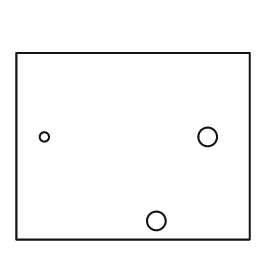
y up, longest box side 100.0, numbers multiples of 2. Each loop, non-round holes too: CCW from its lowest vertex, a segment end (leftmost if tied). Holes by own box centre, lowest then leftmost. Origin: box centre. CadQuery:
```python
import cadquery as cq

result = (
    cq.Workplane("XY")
    .moveTo(-50.0, -40.0)
    .lineTo(50.0, -40.0)
    .lineTo(50.0, 40.0)
    .lineTo(-50.0, 40.0)
    .close()
    .moveTo(10.0, -32.0)
    .circle(4.0)
    .moveTo(-38.0, 4.0)
    .circle(2.0)
    .moveTo(32.0, 4.0)
    .circle(4.0)
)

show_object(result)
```